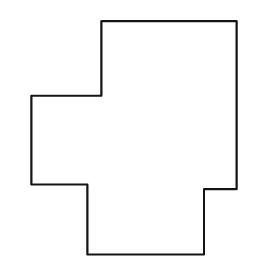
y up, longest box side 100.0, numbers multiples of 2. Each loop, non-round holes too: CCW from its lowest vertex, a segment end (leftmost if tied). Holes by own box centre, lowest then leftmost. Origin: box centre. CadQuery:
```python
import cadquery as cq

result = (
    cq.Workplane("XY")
    .moveTo(-20.0, -50.0)
    .lineTo(30.0, -50.0)
    .lineTo(30.0, -22.0)
    .lineTo(44.0, -22.0)
    .lineTo(44.0, 50.0)
    .lineTo(-14.0, 50.0)
    .lineTo(-14.0, 18.0)
    .lineTo(-44.0, 18.0)
    .lineTo(-44.0, -20.0)
    .lineTo(-20.0, -20.0)
    .close()
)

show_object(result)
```